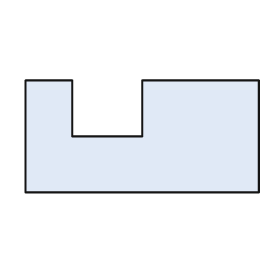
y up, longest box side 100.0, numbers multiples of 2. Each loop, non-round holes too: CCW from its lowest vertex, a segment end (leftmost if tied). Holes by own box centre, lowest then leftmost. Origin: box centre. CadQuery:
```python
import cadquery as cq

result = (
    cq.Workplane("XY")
    .moveTo(-50.0, -24.0)
    .lineTo(50.0, -24.0)
    .lineTo(50.0, 24.0)
    .lineTo(0.0, 24.0)
    .lineTo(0.0, 0.0)
    .lineTo(-30.0, 0.0)
    .lineTo(-30.0, 24.0)
    .lineTo(-50.0, 24.0)
    .close()
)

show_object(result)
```